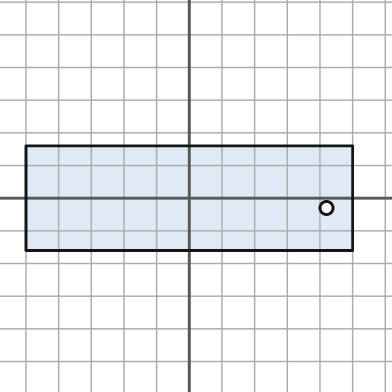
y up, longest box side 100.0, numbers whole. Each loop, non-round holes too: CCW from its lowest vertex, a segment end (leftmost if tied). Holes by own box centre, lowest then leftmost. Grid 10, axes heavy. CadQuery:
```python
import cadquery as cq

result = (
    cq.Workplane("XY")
    .moveTo(-50.0, -16.0)
    .lineTo(50.0, -16.0)
    .lineTo(50.0, 16.0)
    .lineTo(-50.0, 16.0)
    .close()
    .moveTo(42.0, -3.0)
    .circle(2.0)
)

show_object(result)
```